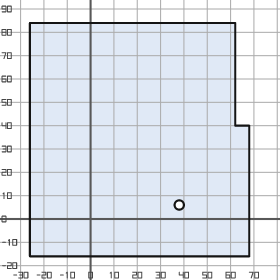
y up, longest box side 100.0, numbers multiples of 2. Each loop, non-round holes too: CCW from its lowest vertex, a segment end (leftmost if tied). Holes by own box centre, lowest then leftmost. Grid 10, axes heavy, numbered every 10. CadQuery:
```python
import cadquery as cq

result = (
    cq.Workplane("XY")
    .moveTo(-26.0, -16.0)
    .lineTo(68.0, -16.0)
    .lineTo(68.0, 40.0)
    .lineTo(62.0, 40.0)
    .lineTo(62.0, 84.0)
    .lineTo(-26.0, 84.0)
    .close()
    .moveTo(38.0, 6.0)
    .circle(2.0)
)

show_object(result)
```